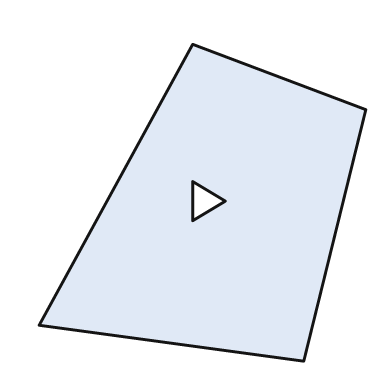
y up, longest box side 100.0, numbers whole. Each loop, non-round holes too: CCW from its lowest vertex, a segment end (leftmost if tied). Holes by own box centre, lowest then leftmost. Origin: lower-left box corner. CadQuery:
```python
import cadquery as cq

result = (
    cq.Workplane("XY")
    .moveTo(81.0, 0.0)
    .lineTo(100.0, 77.0)
    .lineTo(47.0, 97.0)
    .lineTo(0.0, 11.0)
    .close()
    .moveTo(47.0, 43.0)
    .lineTo(57.0, 49.0)
    .lineTo(47.0, 55.0)
    .close()
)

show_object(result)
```